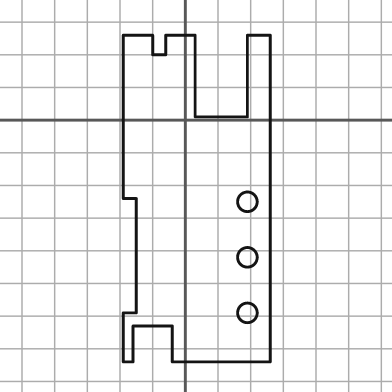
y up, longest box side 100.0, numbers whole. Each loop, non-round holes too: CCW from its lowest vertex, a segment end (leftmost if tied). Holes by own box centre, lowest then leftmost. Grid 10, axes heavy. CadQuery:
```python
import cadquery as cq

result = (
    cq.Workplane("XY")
    .moveTo(-19.0, -74.0)
    .lineTo(-16.0, -74.0)
    .lineTo(-16.0, -63.0)
    .lineTo(-4.0, -63.0)
    .lineTo(-4.0, -74.0)
    .lineTo(26.0, -74.0)
    .lineTo(26.0, 26.0)
    .lineTo(19.0, 26.0)
    .lineTo(19.0, 1.0)
    .lineTo(3.0, 1.0)
    .lineTo(3.0, 26.0)
    .lineTo(-6.0, 26.0)
    .lineTo(-6.0, 20.0)
    .lineTo(-10.0, 20.0)
    .lineTo(-10.0, 26.0)
    .lineTo(-19.0, 26.0)
    .lineTo(-19.0, -24.0)
    .lineTo(-15.0, -24.0)
    .lineTo(-15.0, -59.0)
    .lineTo(-19.0, -59.0)
    .close()
    .moveTo(19.0, -59.0)
    .circle(3.0)
    .moveTo(19.0, -42.0)
    .circle(3.0)
    .moveTo(19.0, -25.0)
    .circle(3.0)
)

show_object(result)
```